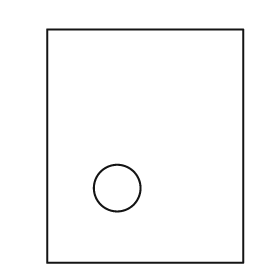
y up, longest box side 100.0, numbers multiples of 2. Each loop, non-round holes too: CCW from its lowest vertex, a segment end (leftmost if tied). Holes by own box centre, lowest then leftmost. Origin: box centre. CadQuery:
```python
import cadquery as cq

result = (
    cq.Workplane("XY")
    .moveTo(-42.0, -50.0)
    .lineTo(42.0, -50.0)
    .lineTo(42.0, 50.0)
    .lineTo(-42.0, 50.0)
    .close()
    .moveTo(-12.0, -18.0)
    .circle(10.0)
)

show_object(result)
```